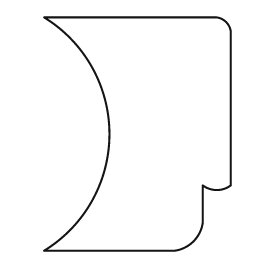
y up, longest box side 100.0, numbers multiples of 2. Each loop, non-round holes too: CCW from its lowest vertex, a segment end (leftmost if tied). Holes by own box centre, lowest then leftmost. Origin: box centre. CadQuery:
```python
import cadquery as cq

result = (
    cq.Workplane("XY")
    .moveTo(-40.0, -50.0)
    .lineTo(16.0, -50.0)
    .threePointArc((24.0, -46.0), (28.0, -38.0))
    .lineTo(28.0, -22.0)
    .threePointArc((34.0, -24.0), (40.0, -22.0))
    .lineTo(40.0, 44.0)
    .threePointArc((38.0, 48.0), (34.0, 50.0))
    .lineTo(-40.0, 50.0)
    .threePointArc((-12.0, 0.0), (-40.0, -50.0))
    .close()
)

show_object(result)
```